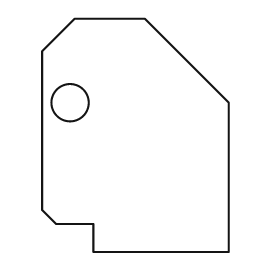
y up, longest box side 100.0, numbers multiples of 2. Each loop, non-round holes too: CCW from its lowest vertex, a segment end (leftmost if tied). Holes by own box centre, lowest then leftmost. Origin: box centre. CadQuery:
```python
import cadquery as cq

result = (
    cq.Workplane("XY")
    .moveTo(-18.0, -50.0)
    .lineTo(40.0, -50.0)
    .lineTo(40.0, 14.0)
    .lineTo(4.0, 50.0)
    .lineTo(-26.0, 50.0)
    .lineTo(-40.0, 36.0)
    .lineTo(-40.0, -32.0)
    .lineTo(-34.0, -38.0)
    .lineTo(-18.0, -38.0)
    .close()
    .moveTo(-28.0, 14.0)
    .circle(8.0)
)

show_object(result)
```